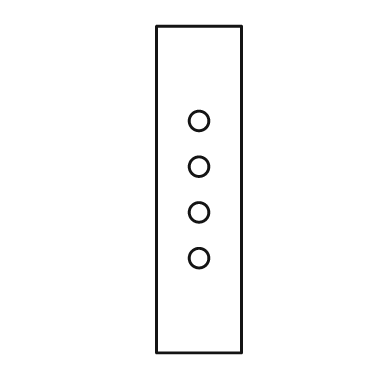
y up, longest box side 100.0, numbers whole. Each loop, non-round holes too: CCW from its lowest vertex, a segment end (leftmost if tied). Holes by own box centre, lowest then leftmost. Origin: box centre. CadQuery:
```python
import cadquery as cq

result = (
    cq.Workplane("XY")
    .moveTo(-13.0, -50.0)
    .lineTo(13.0, -50.0)
    .lineTo(13.0, 50.0)
    .lineTo(-13.0, 50.0)
    .close()
    .moveTo(0.0, -21.0)
    .circle(3.0)
    .moveTo(0.0, -7.0)
    .circle(3.0)
    .moveTo(0.0, 7.0)
    .circle(3.0)
    .moveTo(0.0, 21.0)
    .circle(3.0)
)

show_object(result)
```